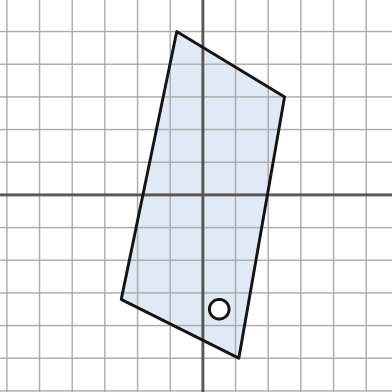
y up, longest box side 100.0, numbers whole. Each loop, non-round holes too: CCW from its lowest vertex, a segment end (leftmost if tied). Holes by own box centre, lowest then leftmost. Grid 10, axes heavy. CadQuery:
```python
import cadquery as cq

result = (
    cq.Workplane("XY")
    .moveTo(11.0, -50.0)
    .lineTo(25.0, 30.0)
    .lineTo(-8.0, 50.0)
    .lineTo(-25.0, -32.0)
    .close()
    .moveTo(5.0, -35.0)
    .circle(3.0)
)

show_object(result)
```